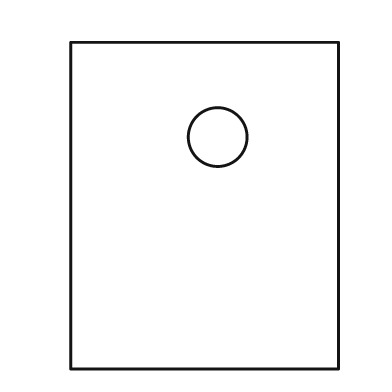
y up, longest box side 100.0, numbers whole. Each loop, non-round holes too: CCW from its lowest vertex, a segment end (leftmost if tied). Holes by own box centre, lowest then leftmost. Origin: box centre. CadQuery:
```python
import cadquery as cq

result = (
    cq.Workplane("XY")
    .moveTo(-41.0, -50.0)
    .lineTo(41.0, -50.0)
    .lineTo(41.0, 50.0)
    .lineTo(-41.0, 50.0)
    .close()
    .moveTo(4.0, 21.0)
    .circle(9.0)
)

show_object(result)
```